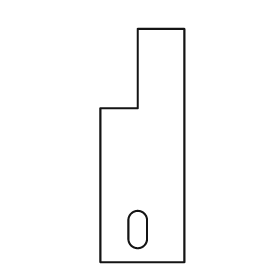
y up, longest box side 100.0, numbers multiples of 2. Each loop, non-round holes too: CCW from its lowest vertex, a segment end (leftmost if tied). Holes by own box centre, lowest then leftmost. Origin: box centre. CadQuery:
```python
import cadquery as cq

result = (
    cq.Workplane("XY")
    .moveTo(-18.0, -50.0)
    .lineTo(18.0, -50.0)
    .lineTo(18.0, 50.0)
    .lineTo(-2.0, 50.0)
    .lineTo(-2.0, 16.0)
    .lineTo(-18.0, 16.0)
    .close()
    .moveTo(-6.0, -40.0)
    .threePointArc((-2.0, -44.0), (2.0, -40.0))
    .lineTo(2.0, -32.0)
    .threePointArc((-2.0, -28.0), (-6.0, -32.0))
    .close()
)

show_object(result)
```